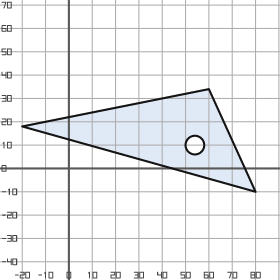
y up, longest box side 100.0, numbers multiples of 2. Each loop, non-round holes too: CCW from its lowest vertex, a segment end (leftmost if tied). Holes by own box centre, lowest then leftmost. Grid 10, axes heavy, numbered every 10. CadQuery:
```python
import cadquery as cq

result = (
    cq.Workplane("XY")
    .moveTo(80.0, -10.0)
    .lineTo(60.0, 34.0)
    .lineTo(-20.0, 18.0)
    .close()
    .moveTo(54.0, 10.0)
    .circle(4.0)
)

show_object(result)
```